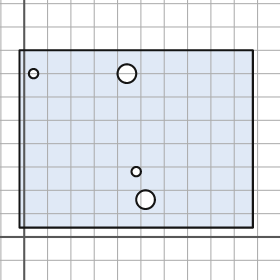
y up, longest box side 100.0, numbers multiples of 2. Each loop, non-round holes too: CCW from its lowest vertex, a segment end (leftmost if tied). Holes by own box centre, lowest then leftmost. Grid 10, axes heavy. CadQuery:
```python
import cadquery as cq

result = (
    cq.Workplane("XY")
    .moveTo(-2.0, 4.0)
    .lineTo(98.0, 4.0)
    .lineTo(98.0, 80.0)
    .lineTo(-2.0, 80.0)
    .close()
    .moveTo(52.0, 16.0)
    .circle(4.0)
    .moveTo(48.0, 28.0)
    .circle(2.0)
    .moveTo(4.0, 70.0)
    .circle(2.0)
    .moveTo(44.0, 70.0)
    .circle(4.0)
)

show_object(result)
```